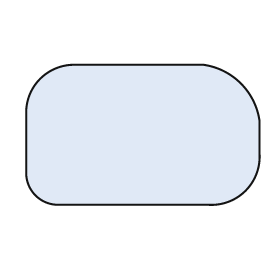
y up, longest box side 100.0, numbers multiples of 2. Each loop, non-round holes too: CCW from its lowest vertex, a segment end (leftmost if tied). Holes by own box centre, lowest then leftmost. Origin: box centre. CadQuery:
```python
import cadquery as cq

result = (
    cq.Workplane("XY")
    .moveTo(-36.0, -30.0)
    .lineTo(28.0, -30.0)
    .threePointArc((44.0, -24.0), (50.0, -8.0))
    .lineTo(50.0, 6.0)
    .threePointArc((42.0, 22.0), (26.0, 30.0))
    .lineTo(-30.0, 30.0)
    .threePointArc((-44.0, 24.0), (-50.0, 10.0))
    .lineTo(-50.0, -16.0)
    .threePointArc((-46.0, -26.0), (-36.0, -30.0))
    .close()
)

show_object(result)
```